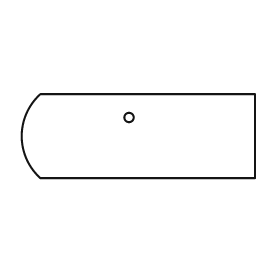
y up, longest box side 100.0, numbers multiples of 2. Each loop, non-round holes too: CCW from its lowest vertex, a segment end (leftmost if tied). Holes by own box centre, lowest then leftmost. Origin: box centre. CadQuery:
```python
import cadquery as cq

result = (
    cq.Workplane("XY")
    .moveTo(-42.0, -18.0)
    .lineTo(50.0, -18.0)
    .lineTo(50.0, 18.0)
    .lineTo(-42.0, 18.0)
    .threePointArc((-50.0, 0.0), (-42.0, -18.0))
    .close()
    .moveTo(-4.0, 8.0)
    .circle(2.0)
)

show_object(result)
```